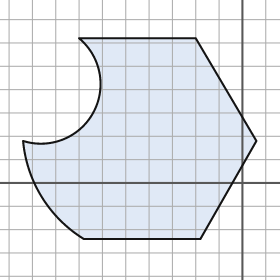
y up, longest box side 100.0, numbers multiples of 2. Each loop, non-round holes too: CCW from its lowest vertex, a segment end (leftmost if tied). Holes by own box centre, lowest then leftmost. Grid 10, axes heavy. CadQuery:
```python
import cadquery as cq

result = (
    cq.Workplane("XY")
    .moveTo(-68.0, -24.0)
    .lineTo(-18.0, -24.0)
    .lineTo(6.0, 18.0)
    .lineTo(-20.0, 62.0)
    .lineTo(-70.0, 62.0)
    .threePointArc((-64.0, 30.0), (-94.0, 18.0))
    .threePointArc((-86.0, -6.0), (-68.0, -24.0))
    .close()
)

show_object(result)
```